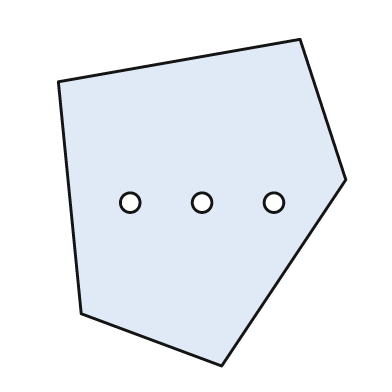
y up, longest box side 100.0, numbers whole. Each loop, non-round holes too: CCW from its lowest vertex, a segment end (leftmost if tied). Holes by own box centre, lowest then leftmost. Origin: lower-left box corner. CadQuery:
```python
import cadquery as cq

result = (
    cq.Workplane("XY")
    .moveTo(50.0, 0.0)
    .lineTo(88.0, 57.0)
    .lineTo(74.0, 100.0)
    .lineTo(0.0, 87.0)
    .lineTo(7.0, 16.0)
    .close()
    .moveTo(22.0, 50.0)
    .circle(3.0)
    .moveTo(44.0, 50.0)
    .circle(3.0)
    .moveTo(66.0, 50.0)
    .circle(3.0)
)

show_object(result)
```